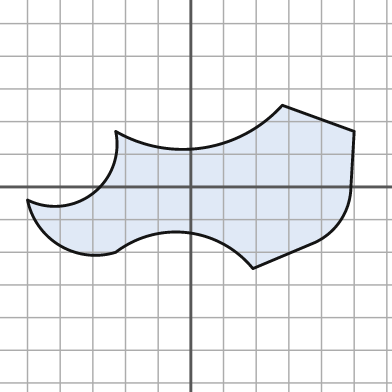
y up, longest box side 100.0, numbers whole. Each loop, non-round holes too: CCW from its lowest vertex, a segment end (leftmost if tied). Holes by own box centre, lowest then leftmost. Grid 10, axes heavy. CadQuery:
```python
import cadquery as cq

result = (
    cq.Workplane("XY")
    .moveTo(19.0, -25.0)
    .lineTo(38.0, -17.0)
    .threePointArc((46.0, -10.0), (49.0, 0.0))
    .lineTo(50.0, 17.0)
    .lineTo(28.0, 25.0)
    .threePointArc((4.0, 12.0), (-23.0, 17.0))
    .threePointArc((-30.0, -2.0), (-50.0, -4.0))
    .threePointArc((-40.0, -18.0), (-23.0, -20.0))
    .threePointArc((-1.0, -14.0), (19.0, -25.0))
    .close()
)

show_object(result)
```